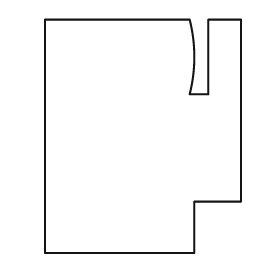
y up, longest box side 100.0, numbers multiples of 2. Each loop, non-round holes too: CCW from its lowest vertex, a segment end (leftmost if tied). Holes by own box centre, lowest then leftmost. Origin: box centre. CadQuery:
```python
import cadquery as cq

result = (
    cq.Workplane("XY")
    .moveTo(-42.0, -50.0)
    .lineTo(22.0, -50.0)
    .lineTo(22.0, -28.0)
    .lineTo(42.0, -28.0)
    .lineTo(42.0, 50.0)
    .lineTo(28.0, 50.0)
    .lineTo(28.0, 18.0)
    .lineTo(20.0, 18.0)
    .threePointArc((22.0, 34.0), (20.0, 50.0))
    .lineTo(-42.0, 50.0)
    .close()
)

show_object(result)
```